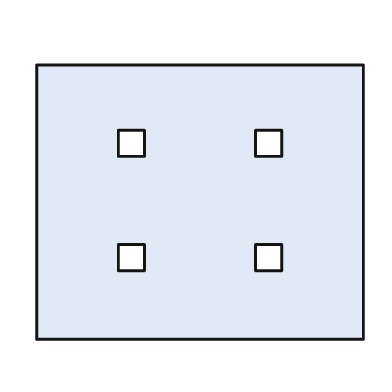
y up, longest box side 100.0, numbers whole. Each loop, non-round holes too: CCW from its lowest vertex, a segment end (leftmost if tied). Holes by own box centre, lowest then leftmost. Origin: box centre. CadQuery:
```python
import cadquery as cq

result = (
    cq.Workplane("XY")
    .moveTo(-50.0, -42.0)
    .lineTo(50.0, -42.0)
    .lineTo(50.0, 42.0)
    .lineTo(-50.0, 42.0)
    .close()
    .moveTo(-25.0, -21.0)
    .lineTo(-17.0, -21.0)
    .lineTo(-17.0, -13.0)
    .lineTo(-25.0, -13.0)
    .close()
    .moveTo(17.0, -21.0)
    .lineTo(25.0, -21.0)
    .lineTo(25.0, -13.0)
    .lineTo(17.0, -13.0)
    .close()
    .moveTo(-25.0, 14.0)
    .lineTo(-17.0, 14.0)
    .lineTo(-17.0, 22.0)
    .lineTo(-25.0, 22.0)
    .close()
    .moveTo(17.0, 14.0)
    .lineTo(25.0, 14.0)
    .lineTo(25.0, 22.0)
    .lineTo(17.0, 22.0)
    .close()
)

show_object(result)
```